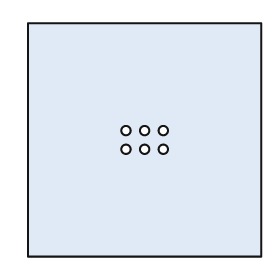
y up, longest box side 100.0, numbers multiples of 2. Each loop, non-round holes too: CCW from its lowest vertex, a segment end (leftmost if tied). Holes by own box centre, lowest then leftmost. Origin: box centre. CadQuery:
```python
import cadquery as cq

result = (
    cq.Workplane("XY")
    .moveTo(-50.0, -50.0)
    .lineTo(50.0, -50.0)
    .lineTo(50.0, 50.0)
    .lineTo(-50.0, 50.0)
    .close()
    .moveTo(-8.0, -4.0)
    .circle(2.0)
    .moveTo(0.0, -4.0)
    .circle(2.0)
    .moveTo(8.0, -4.0)
    .circle(2.0)
    .moveTo(-8.0, 4.0)
    .circle(2.0)
    .moveTo(0.0, 4.0)
    .circle(2.0)
    .moveTo(8.0, 4.0)
    .circle(2.0)
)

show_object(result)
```